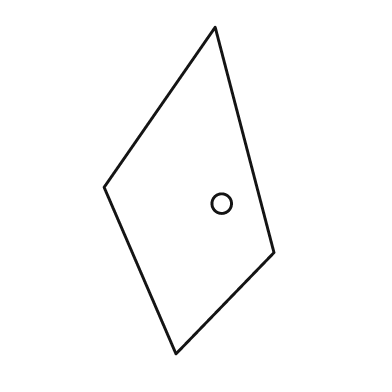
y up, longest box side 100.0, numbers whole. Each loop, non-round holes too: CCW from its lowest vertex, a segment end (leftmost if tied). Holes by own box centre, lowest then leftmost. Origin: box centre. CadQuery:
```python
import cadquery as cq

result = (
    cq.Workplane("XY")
    .moveTo(-4.0, -50.0)
    .lineTo(26.0, -19.0)
    .lineTo(8.0, 50.0)
    .lineTo(-26.0, 1.0)
    .close()
    .moveTo(10.0, -4.0)
    .circle(3.0)
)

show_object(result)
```